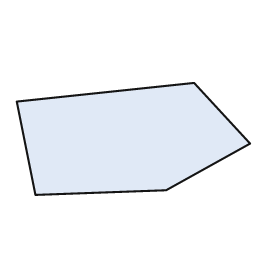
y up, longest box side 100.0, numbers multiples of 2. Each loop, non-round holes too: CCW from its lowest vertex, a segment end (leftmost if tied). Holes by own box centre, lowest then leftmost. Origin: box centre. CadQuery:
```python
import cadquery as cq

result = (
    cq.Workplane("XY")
    .moveTo(-42.0, -24.0)
    .lineTo(14.0, -22.0)
    .lineTo(50.0, -2.0)
    .lineTo(26.0, 24.0)
    .lineTo(-50.0, 16.0)
    .close()
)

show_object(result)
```